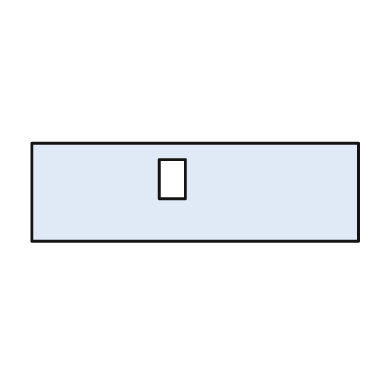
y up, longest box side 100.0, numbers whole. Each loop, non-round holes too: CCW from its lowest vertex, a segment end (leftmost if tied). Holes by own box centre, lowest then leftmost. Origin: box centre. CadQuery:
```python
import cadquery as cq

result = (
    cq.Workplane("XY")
    .moveTo(-50.0, -15.0)
    .lineTo(50.0, -15.0)
    .lineTo(50.0, 15.0)
    .lineTo(-50.0, 15.0)
    .close()
    .moveTo(-11.0, -2.0)
    .lineTo(-3.0, -2.0)
    .lineTo(-3.0, 10.0)
    .lineTo(-11.0, 10.0)
    .close()
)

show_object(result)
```